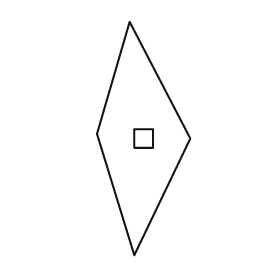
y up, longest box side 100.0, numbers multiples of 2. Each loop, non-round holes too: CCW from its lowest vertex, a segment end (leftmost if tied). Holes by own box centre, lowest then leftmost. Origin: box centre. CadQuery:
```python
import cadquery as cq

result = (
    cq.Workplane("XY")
    .moveTo(-4.0, -50.0)
    .lineTo(20.0, 0.0)
    .lineTo(-6.0, 50.0)
    .lineTo(-20.0, 2.0)
    .close()
    .moveTo(-4.0, -4.0)
    .lineTo(4.0, -4.0)
    .lineTo(4.0, 4.0)
    .lineTo(-4.0, 4.0)
    .close()
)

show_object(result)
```